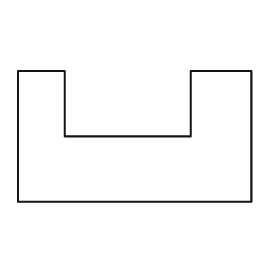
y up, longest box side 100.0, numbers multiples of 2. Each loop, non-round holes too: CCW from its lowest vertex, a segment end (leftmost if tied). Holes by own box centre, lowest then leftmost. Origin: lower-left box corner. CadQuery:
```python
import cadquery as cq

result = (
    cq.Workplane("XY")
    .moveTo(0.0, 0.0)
    .lineTo(100.0, 0.0)
    .lineTo(100.0, 56.0)
    .lineTo(74.0, 56.0)
    .lineTo(74.0, 28.0)
    .lineTo(20.0, 28.0)
    .lineTo(20.0, 56.0)
    .lineTo(0.0, 56.0)
    .close()
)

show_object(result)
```